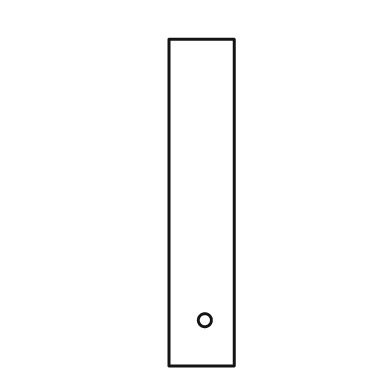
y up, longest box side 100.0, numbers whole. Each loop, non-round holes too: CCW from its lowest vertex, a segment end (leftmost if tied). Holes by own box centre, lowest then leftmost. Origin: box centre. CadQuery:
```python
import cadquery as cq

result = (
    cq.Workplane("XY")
    .moveTo(-10.0, -50.0)
    .lineTo(10.0, -50.0)
    .lineTo(10.0, 50.0)
    .lineTo(-10.0, 50.0)
    .close()
    .moveTo(1.0, -36.0)
    .circle(2.0)
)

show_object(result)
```